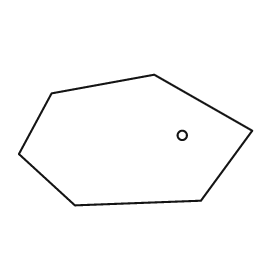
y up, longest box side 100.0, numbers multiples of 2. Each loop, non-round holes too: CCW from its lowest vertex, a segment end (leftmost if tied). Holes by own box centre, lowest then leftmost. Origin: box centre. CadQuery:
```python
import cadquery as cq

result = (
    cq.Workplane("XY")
    .moveTo(-26.0, -28.0)
    .lineTo(28.0, -26.0)
    .lineTo(50.0, 4.0)
    .lineTo(8.0, 28.0)
    .lineTo(-36.0, 20.0)
    .lineTo(-50.0, -6.0)
    .close()
    .moveTo(20.0, 2.0)
    .circle(2.0)
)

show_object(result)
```